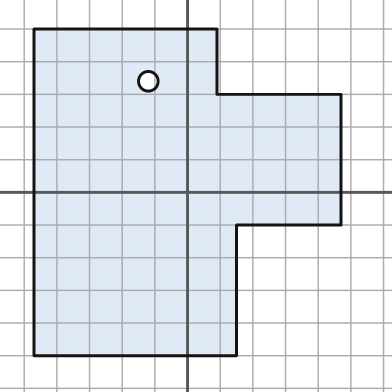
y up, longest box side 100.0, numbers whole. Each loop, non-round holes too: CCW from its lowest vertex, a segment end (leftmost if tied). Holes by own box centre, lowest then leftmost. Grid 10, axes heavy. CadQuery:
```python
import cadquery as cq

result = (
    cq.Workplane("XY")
    .moveTo(-47.0, -50.0)
    .lineTo(15.0, -50.0)
    .lineTo(15.0, -10.0)
    .lineTo(47.0, -10.0)
    .lineTo(47.0, 30.0)
    .lineTo(9.0, 30.0)
    .lineTo(9.0, 50.0)
    .lineTo(-47.0, 50.0)
    .close()
    .moveTo(-12.0, 34.0)
    .circle(3.0)
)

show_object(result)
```